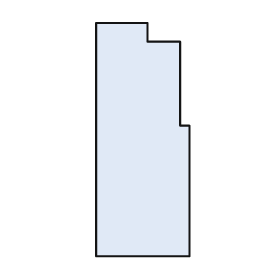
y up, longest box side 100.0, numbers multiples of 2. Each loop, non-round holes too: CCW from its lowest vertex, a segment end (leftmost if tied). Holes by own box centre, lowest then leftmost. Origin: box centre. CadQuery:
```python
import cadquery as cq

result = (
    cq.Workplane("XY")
    .moveTo(-20.0, -50.0)
    .lineTo(20.0, -50.0)
    .lineTo(20.0, 6.0)
    .lineTo(16.0, 6.0)
    .lineTo(16.0, 42.0)
    .lineTo(2.0, 42.0)
    .lineTo(2.0, 50.0)
    .lineTo(-20.0, 50.0)
    .close()
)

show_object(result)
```